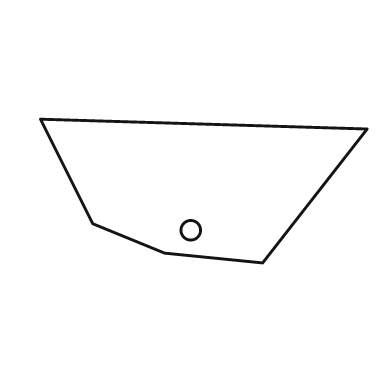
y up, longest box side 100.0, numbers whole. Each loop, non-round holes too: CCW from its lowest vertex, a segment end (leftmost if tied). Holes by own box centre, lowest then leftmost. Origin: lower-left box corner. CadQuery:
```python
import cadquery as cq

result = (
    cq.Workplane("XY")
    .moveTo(68.0, 0.0)
    .lineTo(100.0, 41.0)
    .lineTo(0.0, 44.0)
    .lineTo(16.0, 12.0)
    .lineTo(38.0, 3.0)
    .close()
    .moveTo(46.0, 10.0)
    .circle(3.0)
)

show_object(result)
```